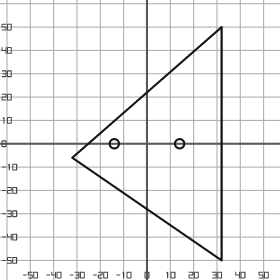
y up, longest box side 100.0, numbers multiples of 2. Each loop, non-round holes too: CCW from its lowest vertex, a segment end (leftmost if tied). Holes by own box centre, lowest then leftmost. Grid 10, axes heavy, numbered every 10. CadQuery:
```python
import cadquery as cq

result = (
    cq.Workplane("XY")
    .moveTo(32.0, -50.0)
    .lineTo(32.0, 50.0)
    .lineTo(-32.0, -6.0)
    .close()
    .moveTo(-14.0, 0.0)
    .circle(2.0)
    .moveTo(14.0, 0.0)
    .circle(2.0)
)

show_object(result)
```